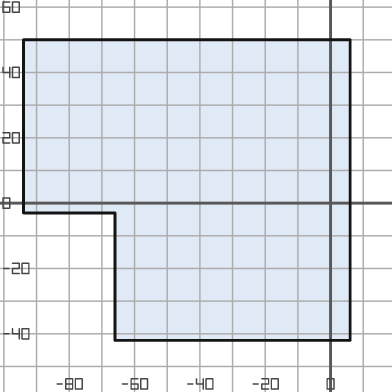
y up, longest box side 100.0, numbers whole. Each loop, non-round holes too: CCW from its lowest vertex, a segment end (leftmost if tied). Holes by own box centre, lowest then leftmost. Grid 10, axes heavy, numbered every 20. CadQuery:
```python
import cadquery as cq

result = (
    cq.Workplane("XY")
    .moveTo(-66.0, -42.0)
    .lineTo(6.0, -42.0)
    .lineTo(6.0, 50.0)
    .lineTo(-94.0, 50.0)
    .lineTo(-94.0, -3.0)
    .lineTo(-66.0, -3.0)
    .close()
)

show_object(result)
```